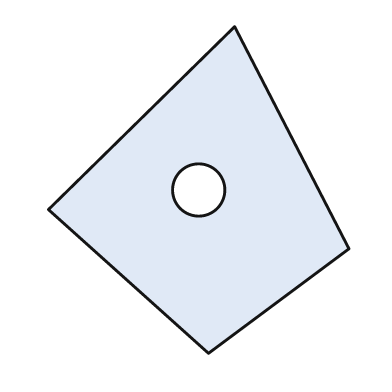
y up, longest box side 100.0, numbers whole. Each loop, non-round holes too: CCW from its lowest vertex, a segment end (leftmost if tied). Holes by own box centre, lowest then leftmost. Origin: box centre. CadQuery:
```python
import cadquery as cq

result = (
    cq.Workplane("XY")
    .moveTo(3.0, -50.0)
    .lineTo(46.0, -18.0)
    .lineTo(11.0, 50.0)
    .lineTo(-46.0, -6.0)
    .close()
    .moveTo(0.0, 0.0)
    .circle(8.0)
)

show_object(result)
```